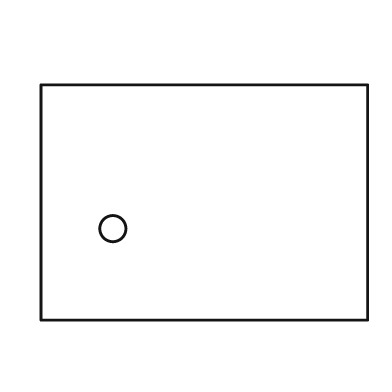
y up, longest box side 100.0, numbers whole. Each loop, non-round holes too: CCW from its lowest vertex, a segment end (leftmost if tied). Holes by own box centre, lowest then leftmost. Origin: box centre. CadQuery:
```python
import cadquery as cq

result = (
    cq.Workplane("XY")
    .moveTo(-50.0, -36.0)
    .lineTo(50.0, -36.0)
    .lineTo(50.0, 36.0)
    .lineTo(-50.0, 36.0)
    .close()
    .moveTo(-28.0, -8.0)
    .circle(4.0)
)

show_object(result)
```